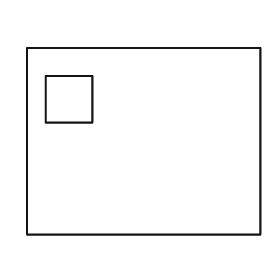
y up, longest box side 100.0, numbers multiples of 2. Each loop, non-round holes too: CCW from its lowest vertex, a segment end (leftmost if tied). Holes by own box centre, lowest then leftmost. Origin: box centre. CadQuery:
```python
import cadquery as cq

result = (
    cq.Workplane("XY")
    .moveTo(-50.0, -40.0)
    .lineTo(50.0, -40.0)
    .lineTo(50.0, 40.0)
    .lineTo(-50.0, 40.0)
    .close()
    .moveTo(-42.0, 8.0)
    .lineTo(-22.0, 8.0)
    .lineTo(-22.0, 28.0)
    .lineTo(-42.0, 28.0)
    .close()
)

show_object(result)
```